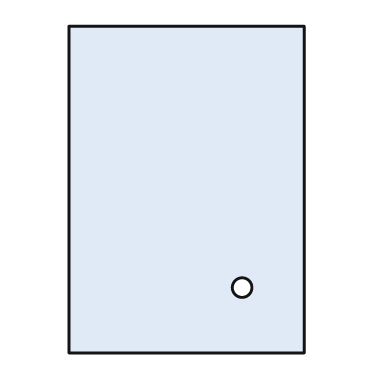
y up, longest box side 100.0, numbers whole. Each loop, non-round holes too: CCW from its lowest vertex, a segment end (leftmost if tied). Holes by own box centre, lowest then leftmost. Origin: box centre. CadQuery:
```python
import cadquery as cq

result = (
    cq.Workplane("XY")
    .moveTo(-36.0, -50.0)
    .lineTo(36.0, -50.0)
    .lineTo(36.0, 50.0)
    .lineTo(-36.0, 50.0)
    .close()
    .moveTo(17.0, -30.0)
    .circle(3.0)
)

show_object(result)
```